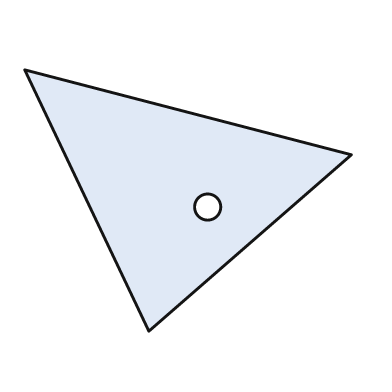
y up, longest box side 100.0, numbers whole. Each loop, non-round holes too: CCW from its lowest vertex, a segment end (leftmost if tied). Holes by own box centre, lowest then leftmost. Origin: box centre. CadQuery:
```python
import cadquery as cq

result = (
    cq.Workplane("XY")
    .moveTo(-12.0, -40.0)
    .lineTo(50.0, 14.0)
    .lineTo(-50.0, 40.0)
    .close()
    .moveTo(6.0, -2.0)
    .circle(4.0)
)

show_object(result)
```